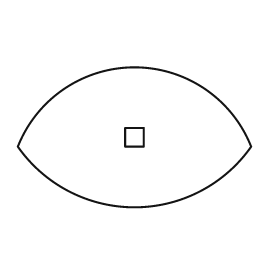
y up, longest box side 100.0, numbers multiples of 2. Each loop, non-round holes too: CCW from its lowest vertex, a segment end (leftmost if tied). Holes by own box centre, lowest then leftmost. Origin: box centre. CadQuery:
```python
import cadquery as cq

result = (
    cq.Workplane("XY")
    .moveTo(-50.0, -4.0)
    .threePointArc((0.0, -30.0), (50.0, -4.0))
    .threePointArc((0.0, 30.0), (-50.0, -4.0))
    .close()
    .moveTo(-4.0, -4.0)
    .lineTo(4.0, -4.0)
    .lineTo(4.0, 4.0)
    .lineTo(-4.0, 4.0)
    .close()
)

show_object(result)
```